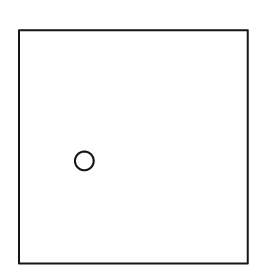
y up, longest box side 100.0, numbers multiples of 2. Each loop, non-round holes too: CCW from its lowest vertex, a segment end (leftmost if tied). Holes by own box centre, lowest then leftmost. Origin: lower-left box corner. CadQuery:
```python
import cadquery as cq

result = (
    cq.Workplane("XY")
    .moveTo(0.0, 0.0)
    .lineTo(98.0, 0.0)
    .lineTo(98.0, 100.0)
    .lineTo(0.0, 100.0)
    .close()
    .moveTo(28.0, 44.0)
    .circle(4.0)
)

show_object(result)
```